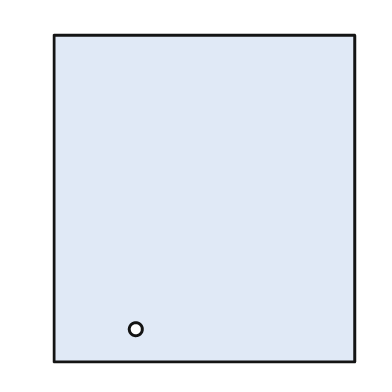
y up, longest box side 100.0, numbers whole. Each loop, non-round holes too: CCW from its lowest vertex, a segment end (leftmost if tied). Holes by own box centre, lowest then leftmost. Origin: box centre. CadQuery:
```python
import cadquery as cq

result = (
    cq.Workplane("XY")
    .moveTo(-46.0, -50.0)
    .lineTo(46.0, -50.0)
    .lineTo(46.0, 50.0)
    .lineTo(-46.0, 50.0)
    .close()
    .moveTo(-21.0, -40.0)
    .circle(2.0)
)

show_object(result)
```